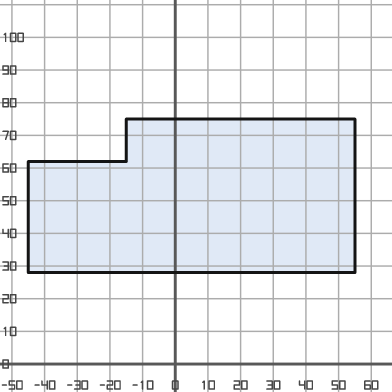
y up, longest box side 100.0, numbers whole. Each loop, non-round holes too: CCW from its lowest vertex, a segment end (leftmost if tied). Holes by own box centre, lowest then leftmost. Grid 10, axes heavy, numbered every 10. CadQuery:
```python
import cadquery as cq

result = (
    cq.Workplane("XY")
    .moveTo(-45.0, 28.0)
    .lineTo(55.0, 28.0)
    .lineTo(55.0, 75.0)
    .lineTo(-15.0, 75.0)
    .lineTo(-15.0, 62.0)
    .lineTo(-45.0, 62.0)
    .close()
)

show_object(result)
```